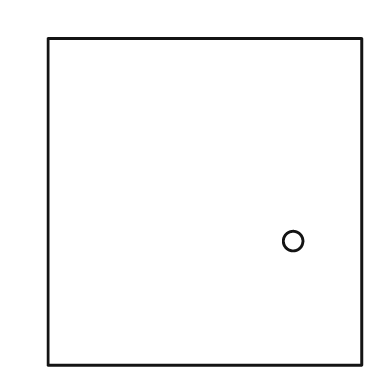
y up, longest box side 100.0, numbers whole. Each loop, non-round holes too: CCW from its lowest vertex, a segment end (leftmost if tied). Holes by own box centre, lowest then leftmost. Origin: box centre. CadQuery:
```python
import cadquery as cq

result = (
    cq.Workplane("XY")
    .moveTo(-48.0, -50.0)
    .lineTo(48.0, -50.0)
    .lineTo(48.0, 50.0)
    .lineTo(-48.0, 50.0)
    .close()
    .moveTo(27.0, -12.0)
    .circle(3.0)
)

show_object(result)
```